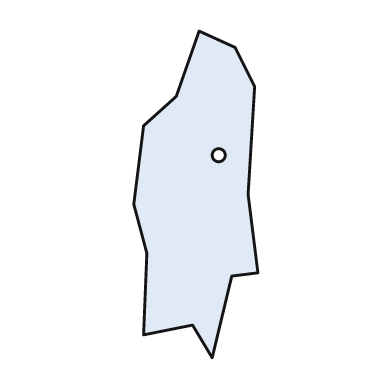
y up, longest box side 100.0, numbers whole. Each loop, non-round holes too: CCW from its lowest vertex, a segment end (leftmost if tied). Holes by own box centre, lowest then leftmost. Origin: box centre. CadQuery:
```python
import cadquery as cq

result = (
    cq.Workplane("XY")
    .moveTo(5.0, -50.0)
    .lineTo(11.0, -25.0)
    .lineTo(19.0, -24.0)
    .lineTo(16.0, 0.0)
    .lineTo(18.0, 33.0)
    .lineTo(12.0, 45.0)
    .lineTo(1.0, 50.0)
    .lineTo(-6.0, 30.0)
    .lineTo(-16.0, 21.0)
    .lineTo(-19.0, -3.0)
    .lineTo(-15.0, -18.0)
    .lineTo(-16.0, -43.0)
    .lineTo(-1.0, -40.0)
    .close()
    .moveTo(7.0, 12.0)
    .circle(2.0)
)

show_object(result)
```